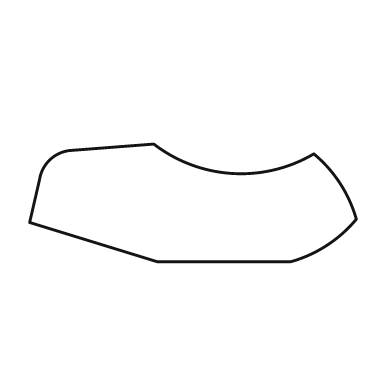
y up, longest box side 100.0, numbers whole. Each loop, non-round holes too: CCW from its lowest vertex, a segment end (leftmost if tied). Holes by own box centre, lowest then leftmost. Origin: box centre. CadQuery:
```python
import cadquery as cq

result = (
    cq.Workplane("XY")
    .moveTo(-11.0, -18.0)
    .lineTo(30.0, -18.0)
    .threePointArc((41.0, -13.0), (50.0, -5.0))
    .threePointArc((45.0, 6.0), (37.0, 15.0))
    .threePointArc((12.0, 9.0), (-12.0, 18.0))
    .lineTo(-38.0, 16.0)
    .threePointArc((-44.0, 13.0), (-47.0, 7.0))
    .lineTo(-50.0, -6.0)
    .close()
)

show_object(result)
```